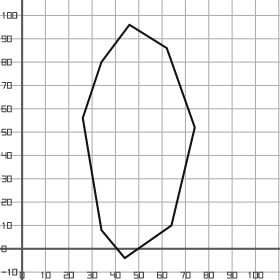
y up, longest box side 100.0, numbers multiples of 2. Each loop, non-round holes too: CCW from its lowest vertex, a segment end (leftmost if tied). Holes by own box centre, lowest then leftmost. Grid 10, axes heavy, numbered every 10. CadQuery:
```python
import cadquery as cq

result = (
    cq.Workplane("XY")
    .moveTo(44.0, -4.0)
    .lineTo(64.0, 10.0)
    .lineTo(74.0, 52.0)
    .lineTo(62.0, 86.0)
    .lineTo(46.0, 96.0)
    .lineTo(34.0, 80.0)
    .lineTo(26.0, 56.0)
    .lineTo(34.0, 8.0)
    .close()
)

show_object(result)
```